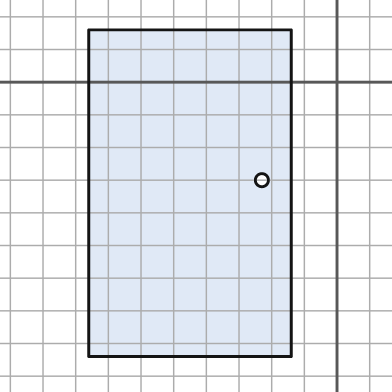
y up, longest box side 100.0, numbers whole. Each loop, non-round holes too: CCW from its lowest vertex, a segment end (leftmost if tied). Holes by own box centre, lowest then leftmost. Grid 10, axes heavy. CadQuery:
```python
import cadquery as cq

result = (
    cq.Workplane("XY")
    .moveTo(-76.0, -84.0)
    .lineTo(-14.0, -84.0)
    .lineTo(-14.0, 16.0)
    .lineTo(-76.0, 16.0)
    .close()
    .moveTo(-23.0, -30.0)
    .circle(2.0)
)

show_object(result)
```